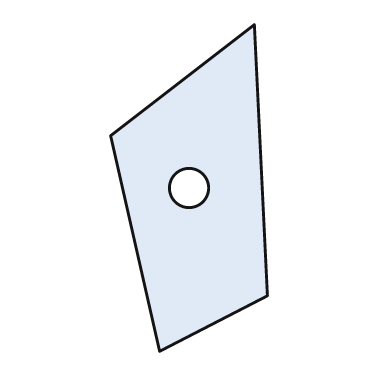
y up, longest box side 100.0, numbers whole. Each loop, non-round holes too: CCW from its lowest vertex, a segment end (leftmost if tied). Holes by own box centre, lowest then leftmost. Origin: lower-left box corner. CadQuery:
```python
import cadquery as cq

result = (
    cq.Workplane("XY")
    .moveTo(15.0, 0.0)
    .lineTo(48.0, 17.0)
    .lineTo(44.0, 100.0)
    .lineTo(0.0, 66.0)
    .close()
    .moveTo(24.0, 50.0)
    .circle(6.0)
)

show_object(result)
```